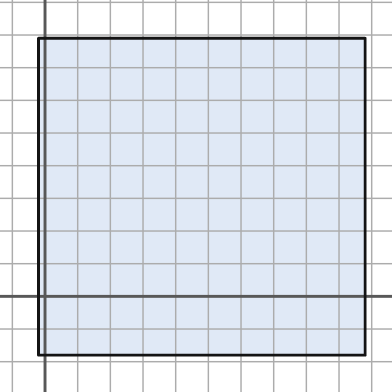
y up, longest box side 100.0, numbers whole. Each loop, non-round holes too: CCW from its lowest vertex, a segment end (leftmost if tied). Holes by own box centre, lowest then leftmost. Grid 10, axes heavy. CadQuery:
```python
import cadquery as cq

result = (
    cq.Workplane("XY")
    .moveTo(-2.0, -18.0)
    .lineTo(98.0, -18.0)
    .lineTo(98.0, 79.0)
    .lineTo(-2.0, 79.0)
    .close()
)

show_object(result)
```